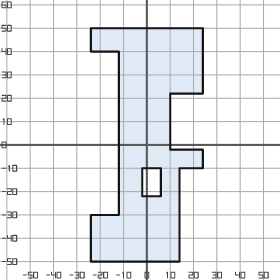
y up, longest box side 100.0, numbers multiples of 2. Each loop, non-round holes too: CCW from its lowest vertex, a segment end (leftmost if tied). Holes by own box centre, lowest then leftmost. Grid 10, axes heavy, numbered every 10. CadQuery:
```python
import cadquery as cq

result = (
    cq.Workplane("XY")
    .moveTo(-24.0, -50.0)
    .lineTo(14.0, -50.0)
    .lineTo(14.0, -10.0)
    .lineTo(24.0, -10.0)
    .lineTo(24.0, -2.0)
    .lineTo(10.0, -2.0)
    .lineTo(10.0, 22.0)
    .lineTo(24.0, 22.0)
    .lineTo(24.0, 50.0)
    .lineTo(-24.0, 50.0)
    .lineTo(-24.0, 40.0)
    .lineTo(-12.0, 40.0)
    .lineTo(-12.0, -30.0)
    .lineTo(-24.0, -30.0)
    .close()
    .moveTo(-2.0, -22.0)
    .lineTo(6.0, -22.0)
    .lineTo(6.0, -10.0)
    .lineTo(-2.0, -10.0)
    .close()
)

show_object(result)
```